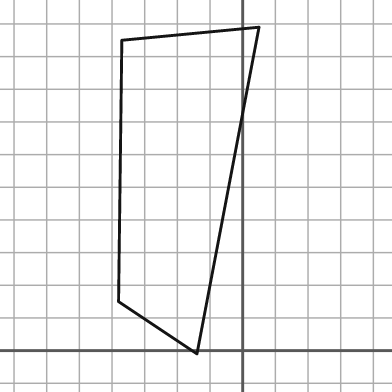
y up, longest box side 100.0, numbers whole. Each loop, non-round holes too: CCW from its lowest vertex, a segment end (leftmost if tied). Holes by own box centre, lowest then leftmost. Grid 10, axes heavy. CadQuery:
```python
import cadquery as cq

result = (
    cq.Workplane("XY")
    .moveTo(-14.0, -1.0)
    .lineTo(5.0, 99.0)
    .lineTo(-37.0, 95.0)
    .lineTo(-38.0, 15.0)
    .close()
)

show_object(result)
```